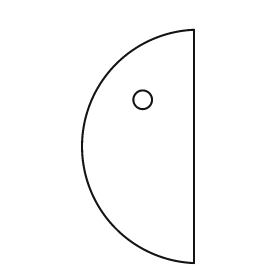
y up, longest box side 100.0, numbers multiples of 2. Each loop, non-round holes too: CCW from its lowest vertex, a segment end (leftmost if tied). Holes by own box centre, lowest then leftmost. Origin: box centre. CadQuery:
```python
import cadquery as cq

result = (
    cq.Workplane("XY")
    .moveTo(24.0, -50.0)
    .lineTo(24.0, 50.0)
    .threePointArc((-24.0, 0.0), (24.0, -50.0))
    .close()
    .moveTo(2.0, 20.0)
    .circle(4.0)
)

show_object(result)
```